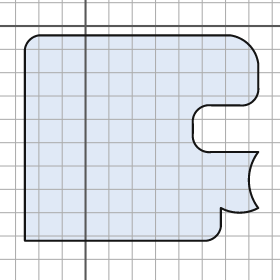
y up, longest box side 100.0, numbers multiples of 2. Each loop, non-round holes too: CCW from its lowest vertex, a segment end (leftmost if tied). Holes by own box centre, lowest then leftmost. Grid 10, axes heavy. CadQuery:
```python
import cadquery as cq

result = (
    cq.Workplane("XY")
    .moveTo(-26.0, -92.0)
    .lineTo(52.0, -92.0)
    .threePointArc((56.0, -90.0), (58.0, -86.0))
    .lineTo(58.0, -78.0)
    .threePointArc((66.0, -80.0), (74.0, -78.0))
    .threePointArc((70.0, -66.0), (74.0, -54.0))
    .lineTo(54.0, -54.0)
    .threePointArc((48.0, -52.0), (46.0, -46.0))
    .lineTo(46.0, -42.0)
    .threePointArc((48.0, -36.0), (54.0, -34.0))
    .lineTo(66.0, -34.0)
    .threePointArc((72.0, -32.0), (74.0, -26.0))
    .lineTo(74.0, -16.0)
    .threePointArc((70.0, -8.0), (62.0, -4.0))
    .lineTo(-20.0, -4.0)
    .threePointArc((-24.0, -6.0), (-26.0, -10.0))
    .close()
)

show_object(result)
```